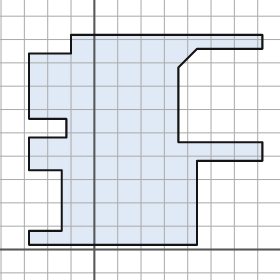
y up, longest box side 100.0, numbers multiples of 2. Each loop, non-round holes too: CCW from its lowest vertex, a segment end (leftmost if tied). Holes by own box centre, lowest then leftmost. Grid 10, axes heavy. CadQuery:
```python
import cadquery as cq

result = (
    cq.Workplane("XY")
    .moveTo(-28.0, 2.0)
    .lineTo(44.0, 2.0)
    .lineTo(44.0, 38.0)
    .lineTo(72.0, 38.0)
    .lineTo(72.0, 46.0)
    .lineTo(36.0, 46.0)
    .lineTo(36.0, 78.0)
    .lineTo(44.0, 86.0)
    .lineTo(72.0, 86.0)
    .lineTo(72.0, 92.0)
    .lineTo(-10.0, 92.0)
    .lineTo(-10.0, 84.0)
    .lineTo(-28.0, 84.0)
    .lineTo(-28.0, 56.0)
    .lineTo(-12.0, 56.0)
    .lineTo(-12.0, 48.0)
    .lineTo(-28.0, 48.0)
    .lineTo(-28.0, 34.0)
    .lineTo(-14.0, 34.0)
    .lineTo(-14.0, 8.0)
    .lineTo(-28.0, 8.0)
    .close()
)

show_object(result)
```